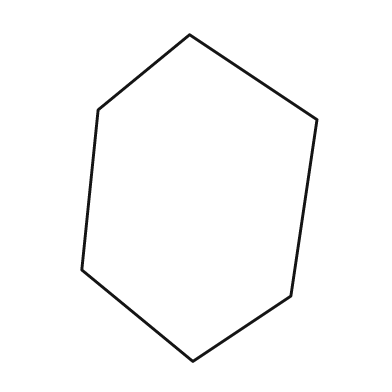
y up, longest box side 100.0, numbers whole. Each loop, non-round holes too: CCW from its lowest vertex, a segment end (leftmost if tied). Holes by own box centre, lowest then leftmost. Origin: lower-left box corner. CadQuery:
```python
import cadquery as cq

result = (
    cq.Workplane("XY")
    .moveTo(34.0, 0.0)
    .lineTo(64.0, 20.0)
    .lineTo(72.0, 74.0)
    .lineTo(33.0, 100.0)
    .lineTo(5.0, 77.0)
    .lineTo(0.0, 28.0)
    .close()
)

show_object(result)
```